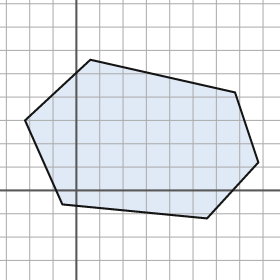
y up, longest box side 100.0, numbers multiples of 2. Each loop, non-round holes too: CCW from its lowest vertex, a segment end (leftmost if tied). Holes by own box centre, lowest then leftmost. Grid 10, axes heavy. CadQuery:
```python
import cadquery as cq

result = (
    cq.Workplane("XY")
    .moveTo(56.0, -12.0)
    .lineTo(78.0, 12.0)
    .lineTo(68.0, 42.0)
    .lineTo(6.0, 56.0)
    .lineTo(-22.0, 30.0)
    .lineTo(-6.0, -6.0)
    .close()
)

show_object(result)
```